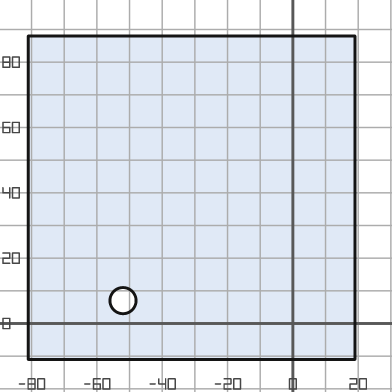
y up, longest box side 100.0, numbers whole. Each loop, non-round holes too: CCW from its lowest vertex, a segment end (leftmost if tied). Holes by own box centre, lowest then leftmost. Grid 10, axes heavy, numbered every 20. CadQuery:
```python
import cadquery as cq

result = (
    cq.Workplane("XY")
    .moveTo(-81.0, -11.0)
    .lineTo(19.0, -11.0)
    .lineTo(19.0, 88.0)
    .lineTo(-81.0, 88.0)
    .close()
    .moveTo(-52.0, 7.0)
    .circle(4.0)
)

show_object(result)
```